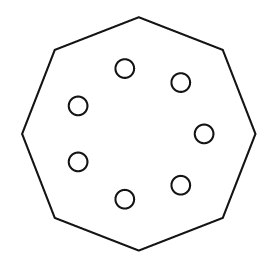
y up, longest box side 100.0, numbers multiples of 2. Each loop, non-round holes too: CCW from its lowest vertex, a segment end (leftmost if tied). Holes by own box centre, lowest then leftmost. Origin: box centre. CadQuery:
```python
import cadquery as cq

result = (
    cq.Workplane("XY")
    .moveTo(0.0, -50.0)
    .lineTo(36.0, -36.0)
    .lineTo(50.0, 0.0)
    .lineTo(36.0, 36.0)
    .lineTo(0.0, 50.0)
    .lineTo(-36.0, 36.0)
    .lineTo(-50.0, 0.0)
    .lineTo(-36.0, -36.0)
    .close()
    .moveTo(-6.0, -28.0)
    .circle(4.0)
    .moveTo(18.0, -22.0)
    .circle(4.0)
    .moveTo(-26.0, -12.0)
    .circle(4.0)
    .moveTo(28.0, 0.0)
    .circle(4.0)
    .moveTo(-26.0, 12.0)
    .circle(4.0)
    .moveTo(18.0, 22.0)
    .circle(4.0)
    .moveTo(-6.0, 28.0)
    .circle(4.0)
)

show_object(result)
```